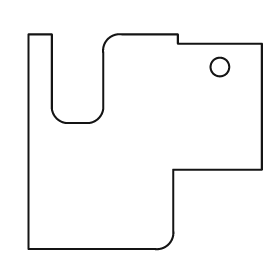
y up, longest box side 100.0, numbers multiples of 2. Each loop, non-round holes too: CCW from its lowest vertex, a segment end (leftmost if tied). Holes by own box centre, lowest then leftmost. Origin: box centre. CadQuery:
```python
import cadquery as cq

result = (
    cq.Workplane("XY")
    .moveTo(-50.0, -46.0)
    .lineTo(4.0, -46.0)
    .threePointArc((10.0, -44.0), (12.0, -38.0))
    .lineTo(12.0, -12.0)
    .lineTo(50.0, -12.0)
    .lineTo(50.0, 42.0)
    .lineTo(14.0, 42.0)
    .lineTo(14.0, 46.0)
    .lineTo(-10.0, 46.0)
    .threePointArc((-16.0, 44.0), (-18.0, 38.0))
    .lineTo(-18.0, 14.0)
    .threePointArc((-20.0, 10.0), (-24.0, 8.0))
    .lineTo(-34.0, 8.0)
    .threePointArc((-38.0, 10.0), (-40.0, 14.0))
    .lineTo(-40.0, 46.0)
    .lineTo(-50.0, 46.0)
    .close()
    .moveTo(32.0, 32.0)
    .circle(4.0)
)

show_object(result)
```